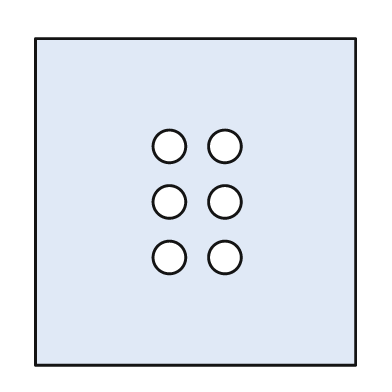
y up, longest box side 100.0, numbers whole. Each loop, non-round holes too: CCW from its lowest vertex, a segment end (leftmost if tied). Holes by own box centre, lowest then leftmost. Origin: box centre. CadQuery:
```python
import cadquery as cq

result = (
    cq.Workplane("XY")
    .moveTo(-49.0, -50.0)
    .lineTo(49.0, -50.0)
    .lineTo(49.0, 50.0)
    .lineTo(-49.0, 50.0)
    .close()
    .moveTo(-8.0, -17.0)
    .circle(5.0)
    .moveTo(9.0, -17.0)
    .circle(5.0)
    .moveTo(-8.0, 0.0)
    .circle(5.0)
    .moveTo(9.0, 0.0)
    .circle(5.0)
    .moveTo(-8.0, 17.0)
    .circle(5.0)
    .moveTo(9.0, 17.0)
    .circle(5.0)
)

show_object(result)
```